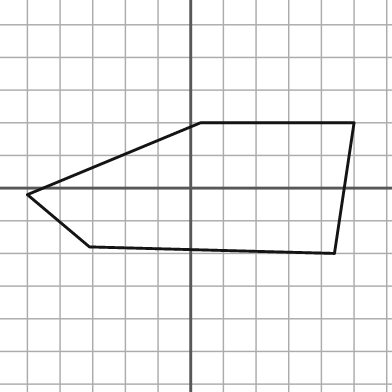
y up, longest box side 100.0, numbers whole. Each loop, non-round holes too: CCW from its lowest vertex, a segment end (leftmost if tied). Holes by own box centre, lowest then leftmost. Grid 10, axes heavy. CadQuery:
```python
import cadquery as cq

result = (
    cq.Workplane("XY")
    .moveTo(44.0, -20.0)
    .lineTo(50.0, 20.0)
    .lineTo(3.0, 20.0)
    .lineTo(-50.0, -2.0)
    .lineTo(-31.0, -18.0)
    .close()
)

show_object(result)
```